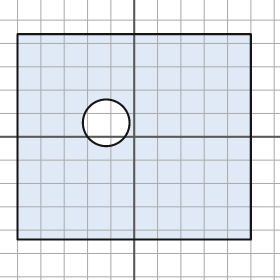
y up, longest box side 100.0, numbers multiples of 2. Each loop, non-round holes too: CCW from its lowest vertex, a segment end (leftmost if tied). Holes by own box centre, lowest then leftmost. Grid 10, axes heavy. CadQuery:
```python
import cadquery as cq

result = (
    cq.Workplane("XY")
    .moveTo(-50.0, -44.0)
    .lineTo(50.0, -44.0)
    .lineTo(50.0, 44.0)
    .lineTo(-50.0, 44.0)
    .close()
    .moveTo(-12.0, 6.0)
    .circle(10.0)
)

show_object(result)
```